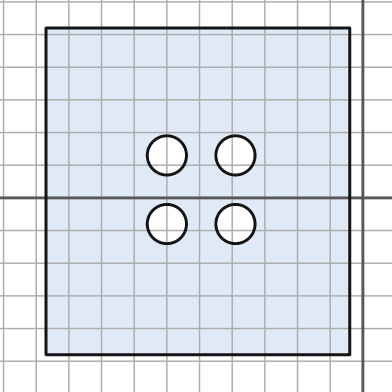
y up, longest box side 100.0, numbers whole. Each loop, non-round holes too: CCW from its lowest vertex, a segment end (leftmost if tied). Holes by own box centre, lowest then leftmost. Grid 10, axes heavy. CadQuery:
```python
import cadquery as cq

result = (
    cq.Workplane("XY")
    .moveTo(-97.0, -48.0)
    .lineTo(-4.0, -48.0)
    .lineTo(-4.0, 52.0)
    .lineTo(-97.0, 52.0)
    .close()
    .moveTo(-60.0, -8.0)
    .circle(6.0)
    .moveTo(-39.0, -8.0)
    .circle(6.0)
    .moveTo(-60.0, 13.0)
    .circle(6.0)
    .moveTo(-39.0, 13.0)
    .circle(6.0)
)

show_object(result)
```